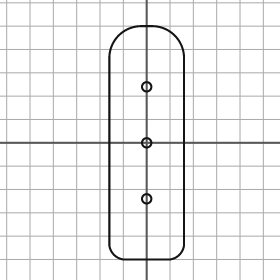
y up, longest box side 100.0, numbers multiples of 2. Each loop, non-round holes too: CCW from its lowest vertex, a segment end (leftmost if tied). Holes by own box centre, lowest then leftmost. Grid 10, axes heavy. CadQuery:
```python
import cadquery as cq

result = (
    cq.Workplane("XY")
    .moveTo(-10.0, -50.0)
    .lineTo(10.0, -50.0)
    .threePointArc((14.0, -48.0), (16.0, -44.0))
    .lineTo(16.0, 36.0)
    .threePointArc((12.0, 46.0), (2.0, 50.0))
    .lineTo(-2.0, 50.0)
    .threePointArc((-12.0, 46.0), (-16.0, 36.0))
    .lineTo(-16.0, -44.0)
    .threePointArc((-14.0, -48.0), (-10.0, -50.0))
    .close()
    .moveTo(0.0, -24.0)
    .circle(2.0)
    .moveTo(0.0, 0.0)
    .circle(2.0)
    .moveTo(0.0, 24.0)
    .circle(2.0)
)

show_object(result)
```